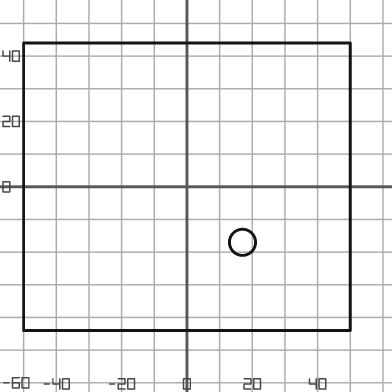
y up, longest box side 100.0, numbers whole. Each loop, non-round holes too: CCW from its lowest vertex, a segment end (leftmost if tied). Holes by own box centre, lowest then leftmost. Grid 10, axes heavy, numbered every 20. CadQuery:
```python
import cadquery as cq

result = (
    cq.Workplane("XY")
    .moveTo(-50.0, -44.0)
    .lineTo(50.0, -44.0)
    .lineTo(50.0, 44.0)
    .lineTo(-50.0, 44.0)
    .close()
    .moveTo(17.0, -17.0)
    .circle(4.0)
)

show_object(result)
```